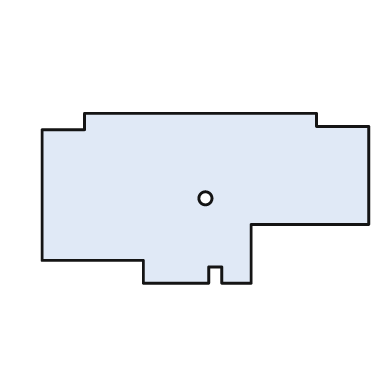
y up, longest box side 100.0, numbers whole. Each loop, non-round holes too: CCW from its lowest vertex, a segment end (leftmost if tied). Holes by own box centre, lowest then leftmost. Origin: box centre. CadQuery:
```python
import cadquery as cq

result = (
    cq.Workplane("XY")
    .moveTo(-19.0, -26.0)
    .lineTo(1.0, -26.0)
    .lineTo(1.0, -21.0)
    .lineTo(5.0, -21.0)
    .lineTo(5.0, -26.0)
    .lineTo(14.0, -26.0)
    .lineTo(14.0, -8.0)
    .lineTo(50.0, -8.0)
    .lineTo(50.0, 22.0)
    .lineTo(34.0, 22.0)
    .lineTo(34.0, 26.0)
    .lineTo(-37.0, 26.0)
    .lineTo(-37.0, 21.0)
    .lineTo(-50.0, 21.0)
    .lineTo(-50.0, -19.0)
    .lineTo(-19.0, -19.0)
    .close()
    .moveTo(0.0, 0.0)
    .circle(2.0)
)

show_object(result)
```